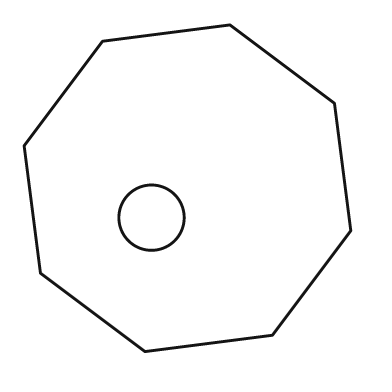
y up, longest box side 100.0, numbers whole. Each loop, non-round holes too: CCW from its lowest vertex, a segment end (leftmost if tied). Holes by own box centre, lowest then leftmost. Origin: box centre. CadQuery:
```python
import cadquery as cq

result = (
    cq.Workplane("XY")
    .moveTo(-13.0, -50.0)
    .lineTo(26.0, -45.0)
    .lineTo(50.0, -13.0)
    .lineTo(45.0, 26.0)
    .lineTo(13.0, 50.0)
    .lineTo(-26.0, 45.0)
    .lineTo(-50.0, 13.0)
    .lineTo(-45.0, -26.0)
    .close()
    .moveTo(-11.0, -9.0)
    .circle(10.0)
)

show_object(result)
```